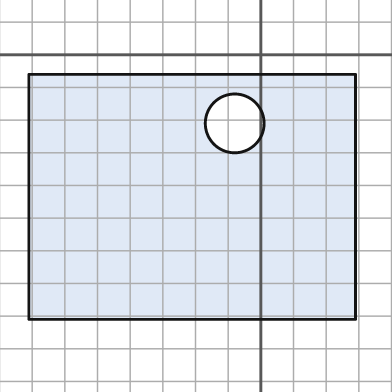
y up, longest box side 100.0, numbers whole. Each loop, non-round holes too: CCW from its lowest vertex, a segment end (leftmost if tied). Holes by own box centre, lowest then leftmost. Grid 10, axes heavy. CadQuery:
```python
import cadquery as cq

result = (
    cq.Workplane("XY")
    .moveTo(-71.0, -81.0)
    .lineTo(29.0, -81.0)
    .lineTo(29.0, -6.0)
    .lineTo(-71.0, -6.0)
    .close()
    .moveTo(-8.0, -21.0)
    .circle(9.0)
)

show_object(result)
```